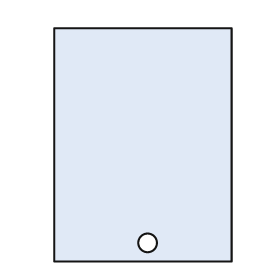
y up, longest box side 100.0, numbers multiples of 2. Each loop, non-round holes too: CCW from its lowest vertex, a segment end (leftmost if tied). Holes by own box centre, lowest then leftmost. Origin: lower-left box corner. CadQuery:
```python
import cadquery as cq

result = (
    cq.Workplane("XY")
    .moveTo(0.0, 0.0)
    .lineTo(76.0, 0.0)
    .lineTo(76.0, 100.0)
    .lineTo(0.0, 100.0)
    .close()
    .moveTo(40.0, 8.0)
    .circle(4.0)
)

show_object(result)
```